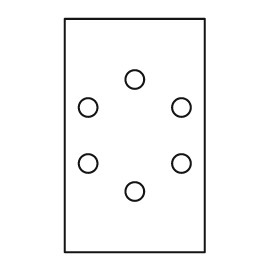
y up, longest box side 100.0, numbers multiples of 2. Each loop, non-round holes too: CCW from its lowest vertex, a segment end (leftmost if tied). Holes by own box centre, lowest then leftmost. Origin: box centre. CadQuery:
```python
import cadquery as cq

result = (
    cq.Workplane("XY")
    .moveTo(-30.0, -50.0)
    .lineTo(30.0, -50.0)
    .lineTo(30.0, 50.0)
    .lineTo(-30.0, 50.0)
    .close()
    .moveTo(0.0, -24.0)
    .circle(4.0)
    .moveTo(-20.0, -12.0)
    .circle(4.0)
    .moveTo(20.0, -12.0)
    .circle(4.0)
    .moveTo(-20.0, 12.0)
    .circle(4.0)
    .moveTo(20.0, 12.0)
    .circle(4.0)
    .moveTo(0.0, 24.0)
    .circle(4.0)
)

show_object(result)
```